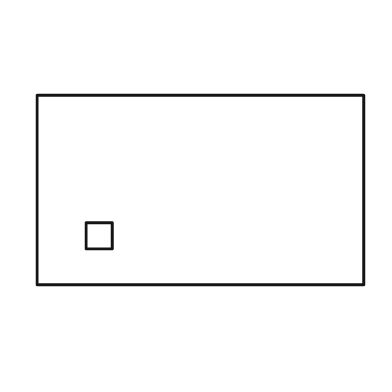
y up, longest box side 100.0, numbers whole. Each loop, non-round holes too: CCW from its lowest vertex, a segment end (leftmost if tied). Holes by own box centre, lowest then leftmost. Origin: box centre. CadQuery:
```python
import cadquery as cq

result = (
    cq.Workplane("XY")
    .moveTo(-50.0, -29.0)
    .lineTo(50.0, -29.0)
    .lineTo(50.0, 29.0)
    .lineTo(-50.0, 29.0)
    .close()
    .moveTo(-35.0, -18.0)
    .lineTo(-27.0, -18.0)
    .lineTo(-27.0, -10.0)
    .lineTo(-35.0, -10.0)
    .close()
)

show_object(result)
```